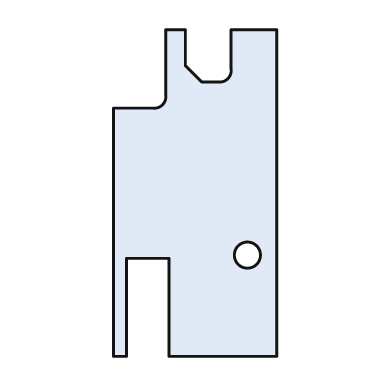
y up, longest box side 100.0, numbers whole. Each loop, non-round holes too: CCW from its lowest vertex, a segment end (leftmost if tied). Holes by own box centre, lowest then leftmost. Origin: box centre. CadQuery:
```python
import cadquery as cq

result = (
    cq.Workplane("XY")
    .moveTo(-25.0, -50.0)
    .lineTo(-21.0, -50.0)
    .lineTo(-21.0, -20.0)
    .lineTo(-8.0, -20.0)
    .lineTo(-8.0, -50.0)
    .lineTo(25.0, -50.0)
    .lineTo(25.0, 50.0)
    .lineTo(11.0, 50.0)
    .lineTo(11.0, 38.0)
    .threePointArc((10.0, 35.0), (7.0, 34.0))
    .lineTo(2.0, 34.0)
    .lineTo(-3.0, 39.0)
    .lineTo(-3.0, 50.0)
    .lineTo(-9.0, 50.0)
    .lineTo(-9.0, 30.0)
    .threePointArc((-10.0, 27.0), (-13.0, 26.0))
    .lineTo(-25.0, 26.0)
    .close()
    .moveTo(16.0, -19.0)
    .circle(4.0)
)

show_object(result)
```